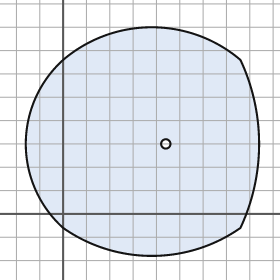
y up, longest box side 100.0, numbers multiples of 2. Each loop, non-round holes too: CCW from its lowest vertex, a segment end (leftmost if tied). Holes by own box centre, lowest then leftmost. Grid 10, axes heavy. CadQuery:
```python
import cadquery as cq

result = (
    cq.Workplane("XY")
    .moveTo(0.0, -6.0)
    .threePointArc((38.0, -18.0), (76.0, -6.0))
    .threePointArc((84.0, 30.0), (76.0, 66.0))
    .threePointArc((38.0, 80.0), (0.0, 66.0))
    .threePointArc((-16.0, 30.0), (0.0, -6.0))
    .close()
    .moveTo(44.0, 30.0)
    .circle(2.0)
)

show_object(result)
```